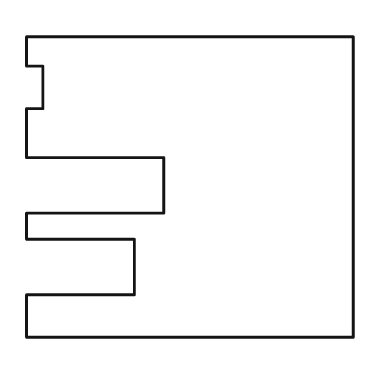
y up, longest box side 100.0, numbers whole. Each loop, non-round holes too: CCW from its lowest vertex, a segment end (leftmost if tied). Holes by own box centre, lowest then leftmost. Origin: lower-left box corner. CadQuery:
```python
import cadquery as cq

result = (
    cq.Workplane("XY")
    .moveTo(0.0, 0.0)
    .lineTo(100.0, 0.0)
    .lineTo(100.0, 92.0)
    .lineTo(0.0, 92.0)
    .lineTo(0.0, 83.0)
    .lineTo(5.0, 83.0)
    .lineTo(5.0, 70.0)
    .lineTo(0.0, 70.0)
    .lineTo(0.0, 55.0)
    .lineTo(42.0, 55.0)
    .lineTo(42.0, 38.0)
    .lineTo(0.0, 38.0)
    .lineTo(0.0, 30.0)
    .lineTo(33.0, 30.0)
    .lineTo(33.0, 13.0)
    .lineTo(0.0, 13.0)
    .close()
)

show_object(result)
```